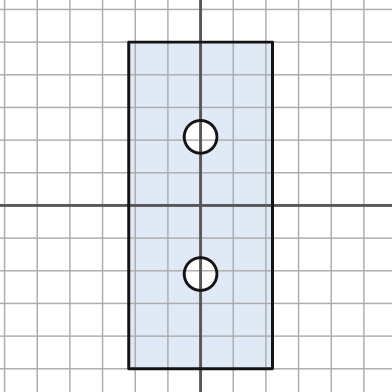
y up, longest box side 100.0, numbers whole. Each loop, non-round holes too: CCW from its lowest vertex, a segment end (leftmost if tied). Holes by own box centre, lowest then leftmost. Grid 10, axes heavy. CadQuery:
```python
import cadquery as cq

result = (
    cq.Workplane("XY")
    .moveTo(-22.0, -50.0)
    .lineTo(22.0, -50.0)
    .lineTo(22.0, 50.0)
    .lineTo(-22.0, 50.0)
    .close()
    .moveTo(0.0, -21.0)
    .circle(5.0)
    .moveTo(0.0, 21.0)
    .circle(5.0)
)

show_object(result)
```